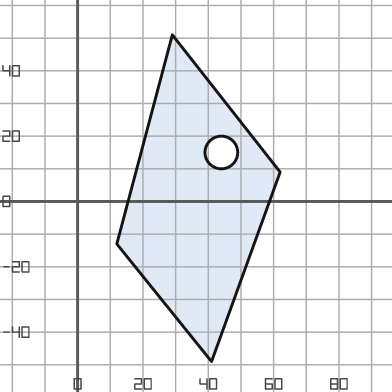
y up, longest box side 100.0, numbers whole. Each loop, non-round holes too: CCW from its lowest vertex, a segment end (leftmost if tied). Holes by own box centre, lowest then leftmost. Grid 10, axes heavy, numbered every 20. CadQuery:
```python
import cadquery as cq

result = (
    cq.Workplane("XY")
    .moveTo(41.0, -49.0)
    .lineTo(62.0, 9.0)
    .lineTo(29.0, 51.0)
    .lineTo(12.0, -13.0)
    .close()
    .moveTo(44.0, 15.0)
    .circle(5.0)
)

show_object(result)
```